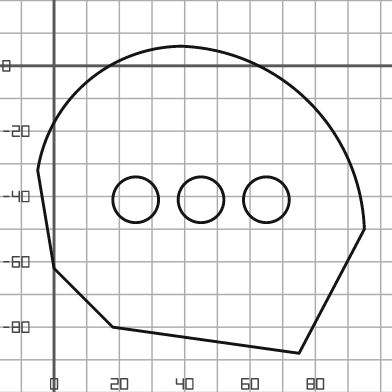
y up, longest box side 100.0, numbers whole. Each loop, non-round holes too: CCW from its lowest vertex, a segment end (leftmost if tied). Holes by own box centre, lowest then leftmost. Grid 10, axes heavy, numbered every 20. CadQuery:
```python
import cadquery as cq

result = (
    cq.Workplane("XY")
    .moveTo(75.0, -88.0)
    .lineTo(95.0, -50.0)
    .threePointArc((78.0, -11.0), (39.0, 6.0))
    .threePointArc((10.0, -5.0), (-5.0, -32.0))
    .lineTo(0.0, -62.0)
    .lineTo(18.0, -80.0)
    .close()
    .moveTo(25.0, -41.0)
    .circle(7.0)
    .moveTo(45.0, -41.0)
    .circle(7.0)
    .moveTo(65.0, -41.0)
    .circle(7.0)
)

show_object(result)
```